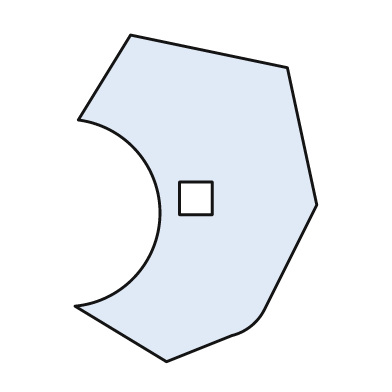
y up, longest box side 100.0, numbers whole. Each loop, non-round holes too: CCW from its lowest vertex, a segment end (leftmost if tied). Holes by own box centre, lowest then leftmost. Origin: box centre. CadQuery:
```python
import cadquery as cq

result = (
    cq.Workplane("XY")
    .moveTo(-9.0, -50.0)
    .lineTo(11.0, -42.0)
    .threePointArc((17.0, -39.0), (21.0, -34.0))
    .lineTo(37.0, -2.0)
    .lineTo(28.0, 40.0)
    .lineTo(-20.0, 50.0)
    .lineTo(-36.0, 24.0)
    .threePointArc((-11.0, -5.0), (-37.0, -33.0))
    .close()
    .moveTo(-5.0, -5.0)
    .lineTo(5.0, -5.0)
    .lineTo(5.0, 5.0)
    .lineTo(-5.0, 5.0)
    .close()
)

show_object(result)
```